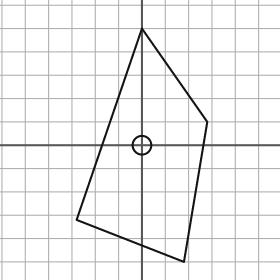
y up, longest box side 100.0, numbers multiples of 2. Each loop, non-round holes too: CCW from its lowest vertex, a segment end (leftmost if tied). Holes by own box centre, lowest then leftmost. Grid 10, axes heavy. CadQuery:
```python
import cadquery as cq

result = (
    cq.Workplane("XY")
    .moveTo(18.0, -50.0)
    .lineTo(28.0, 10.0)
    .lineTo(0.0, 50.0)
    .lineTo(-28.0, -32.0)
    .close()
    .moveTo(0.0, 0.0)
    .circle(4.0)
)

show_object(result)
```